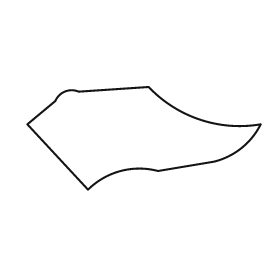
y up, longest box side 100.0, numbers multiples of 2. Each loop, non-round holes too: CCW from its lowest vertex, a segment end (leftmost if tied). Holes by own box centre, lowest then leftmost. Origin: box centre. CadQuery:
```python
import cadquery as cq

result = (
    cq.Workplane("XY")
    .moveTo(-24.0, -22.0)
    .threePointArc((-10.0, -14.0), (6.0, -14.0))
    .lineTo(30.0, -10.0)
    .threePointArc((42.0, -4.0), (50.0, 6.0))
    .threePointArc((24.0, 8.0), (2.0, 22.0))
    .lineTo(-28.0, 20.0)
    .threePointArc((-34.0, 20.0), (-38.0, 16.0))
    .lineTo(-50.0, 6.0)
    .close()
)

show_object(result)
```